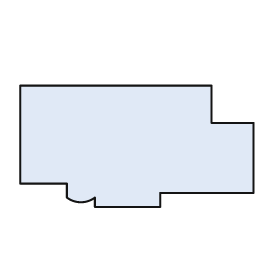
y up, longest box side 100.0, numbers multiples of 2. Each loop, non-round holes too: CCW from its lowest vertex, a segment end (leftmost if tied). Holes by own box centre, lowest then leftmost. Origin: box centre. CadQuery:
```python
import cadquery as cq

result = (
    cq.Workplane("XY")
    .moveTo(-18.0, -26.0)
    .lineTo(10.0, -26.0)
    .lineTo(10.0, -20.0)
    .lineTo(50.0, -20.0)
    .lineTo(50.0, 10.0)
    .lineTo(32.0, 10.0)
    .lineTo(32.0, 26.0)
    .lineTo(-50.0, 26.0)
    .lineTo(-50.0, -16.0)
    .lineTo(-30.0, -16.0)
    .lineTo(-30.0, -22.0)
    .threePointArc((-24.0, -24.0), (-18.0, -22.0))
    .close()
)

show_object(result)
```